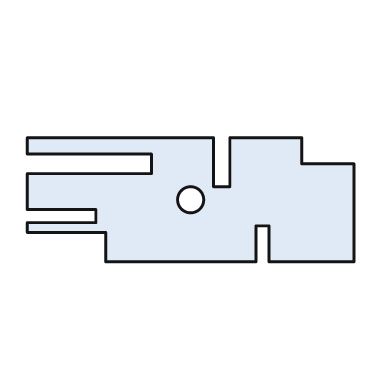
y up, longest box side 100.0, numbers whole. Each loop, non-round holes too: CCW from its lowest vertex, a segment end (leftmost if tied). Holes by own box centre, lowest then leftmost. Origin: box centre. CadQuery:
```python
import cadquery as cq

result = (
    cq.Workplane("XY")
    .moveTo(-26.0, -19.0)
    .lineTo(20.0, -19.0)
    .lineTo(20.0, -8.0)
    .lineTo(24.0, -8.0)
    .lineTo(24.0, -19.0)
    .lineTo(50.0, -19.0)
    .lineTo(50.0, 11.0)
    .lineTo(34.0, 11.0)
    .lineTo(34.0, 19.0)
    .lineTo(12.0, 19.0)
    .lineTo(12.0, 4.0)
    .lineTo(7.0, 4.0)
    .lineTo(7.0, 19.0)
    .lineTo(-50.0, 19.0)
    .lineTo(-50.0, 14.0)
    .lineTo(-12.0, 14.0)
    .lineTo(-12.0, 8.0)
    .lineTo(-50.0, 8.0)
    .lineTo(-50.0, -3.0)
    .lineTo(-29.0, -3.0)
    .lineTo(-29.0, -7.0)
    .lineTo(-50.0, -7.0)
    .lineTo(-50.0, -10.0)
    .lineTo(-26.0, -10.0)
    .close()
    .moveTo(0.0, 0.0)
    .circle(4.0)
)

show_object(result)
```